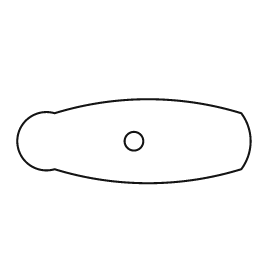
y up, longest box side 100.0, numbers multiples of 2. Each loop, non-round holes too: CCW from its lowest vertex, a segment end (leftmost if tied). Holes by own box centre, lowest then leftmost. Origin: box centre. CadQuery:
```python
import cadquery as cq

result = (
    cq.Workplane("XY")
    .moveTo(-34.0, -12.0)
    .threePointArc((6.0, -18.0), (46.0, -12.0))
    .threePointArc((50.0, 0.0), (46.0, 12.0))
    .threePointArc((6.0, 18.0), (-34.0, 12.0))
    .threePointArc((-50.0, 0.0), (-34.0, -12.0))
    .close()
    .moveTo(0.0, 0.0)
    .circle(4.0)
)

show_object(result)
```